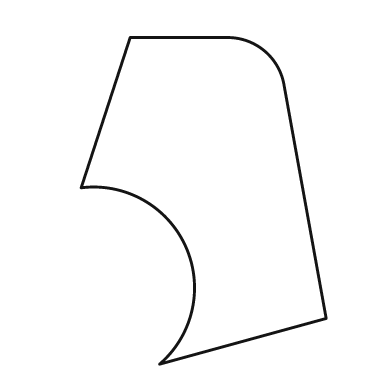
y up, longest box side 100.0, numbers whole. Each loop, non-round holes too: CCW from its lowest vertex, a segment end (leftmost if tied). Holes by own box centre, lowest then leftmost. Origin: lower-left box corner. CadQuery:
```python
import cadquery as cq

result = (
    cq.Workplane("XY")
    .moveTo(24.0, 0.0)
    .lineTo(75.0, 14.0)
    .lineTo(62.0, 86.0)
    .threePointArc((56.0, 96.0), (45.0, 100.0))
    .lineTo(15.0, 100.0)
    .lineTo(0.0, 54.0)
    .threePointArc((32.0, 36.0), (24.0, 0.0))
    .close()
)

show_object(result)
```